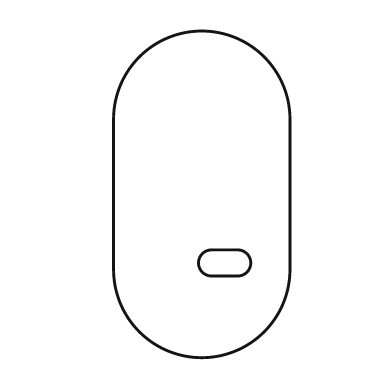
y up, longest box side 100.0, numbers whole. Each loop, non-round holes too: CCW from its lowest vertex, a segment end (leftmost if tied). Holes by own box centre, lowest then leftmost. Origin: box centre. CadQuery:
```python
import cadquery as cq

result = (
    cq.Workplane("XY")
    .moveTo(-27.0, -23.0)
    .threePointArc((0.0, -50.0), (27.0, -23.0))
    .lineTo(27.0, 23.0)
    .threePointArc((0.0, 50.0), (-27.0, 23.0))
    .close()
    .moveTo(3.0, -25.0)
    .lineTo(11.0, -25.0)
    .threePointArc((15.0, -21.0), (11.0, -17.0))
    .lineTo(3.0, -17.0)
    .threePointArc((-1.0, -21.0), (3.0, -25.0))
    .close()
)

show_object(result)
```